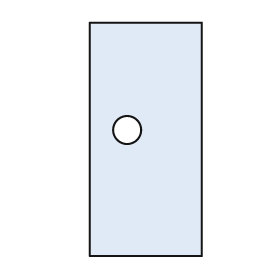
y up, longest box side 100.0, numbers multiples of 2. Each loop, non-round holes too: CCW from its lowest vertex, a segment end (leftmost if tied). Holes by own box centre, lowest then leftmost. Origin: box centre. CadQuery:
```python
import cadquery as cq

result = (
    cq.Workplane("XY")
    .moveTo(-24.0, -50.0)
    .lineTo(24.0, -50.0)
    .lineTo(24.0, 50.0)
    .lineTo(-24.0, 50.0)
    .close()
    .moveTo(-8.0, 4.0)
    .circle(6.0)
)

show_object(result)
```